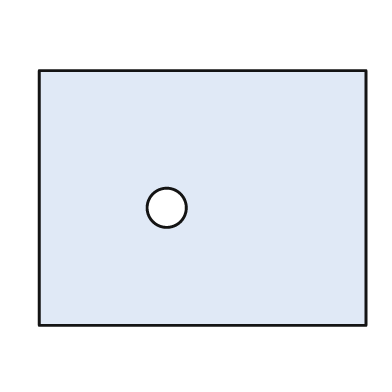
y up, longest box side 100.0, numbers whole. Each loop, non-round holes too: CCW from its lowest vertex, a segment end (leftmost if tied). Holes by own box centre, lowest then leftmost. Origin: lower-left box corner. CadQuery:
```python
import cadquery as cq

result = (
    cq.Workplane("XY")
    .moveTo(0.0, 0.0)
    .lineTo(100.0, 0.0)
    .lineTo(100.0, 78.0)
    .lineTo(0.0, 78.0)
    .close()
    .moveTo(39.0, 36.0)
    .circle(6.0)
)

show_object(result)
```